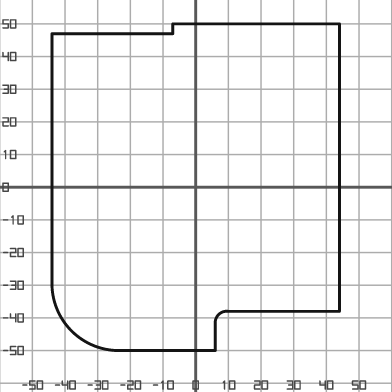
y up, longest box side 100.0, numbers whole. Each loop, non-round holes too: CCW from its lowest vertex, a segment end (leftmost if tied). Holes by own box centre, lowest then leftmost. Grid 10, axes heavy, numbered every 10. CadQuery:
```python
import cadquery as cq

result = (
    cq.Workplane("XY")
    .moveTo(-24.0, -50.0)
    .lineTo(6.0, -50.0)
    .lineTo(6.0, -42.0)
    .threePointArc((7.0, -39.0), (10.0, -38.0))
    .lineTo(44.0, -38.0)
    .lineTo(44.0, 50.0)
    .lineTo(-7.0, 50.0)
    .lineTo(-7.0, 47.0)
    .lineTo(-44.0, 47.0)
    .lineTo(-44.0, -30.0)
    .threePointArc((-38.0, -44.0), (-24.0, -50.0))
    .close()
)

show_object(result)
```